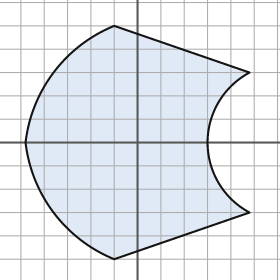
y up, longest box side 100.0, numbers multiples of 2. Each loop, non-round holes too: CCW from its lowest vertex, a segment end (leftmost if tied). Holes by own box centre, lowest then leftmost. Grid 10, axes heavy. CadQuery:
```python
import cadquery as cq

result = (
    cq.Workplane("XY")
    .moveTo(-10.0, -50.0)
    .lineTo(48.0, -30.0)
    .threePointArc((30.0, 0.0), (48.0, 30.0))
    .lineTo(-10.0, 50.0)
    .threePointArc((-36.0, 30.0), (-48.0, 0.0))
    .threePointArc((-36.0, -30.0), (-10.0, -50.0))
    .close()
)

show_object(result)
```